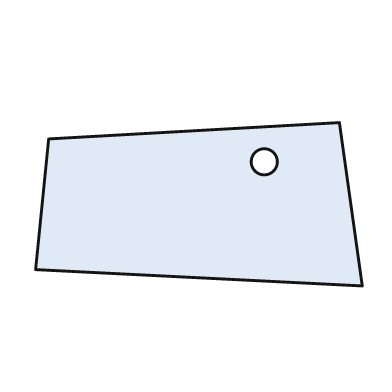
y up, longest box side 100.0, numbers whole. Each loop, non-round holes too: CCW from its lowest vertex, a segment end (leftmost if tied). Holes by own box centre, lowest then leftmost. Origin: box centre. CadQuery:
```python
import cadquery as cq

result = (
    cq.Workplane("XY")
    .moveTo(50.0, -25.0)
    .lineTo(43.0, 25.0)
    .lineTo(-46.0, 20.0)
    .lineTo(-50.0, -20.0)
    .close()
    .moveTo(20.0, 13.0)
    .circle(4.0)
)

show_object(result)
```